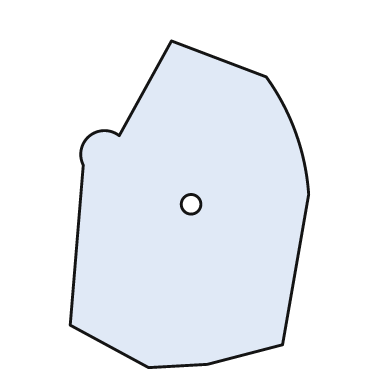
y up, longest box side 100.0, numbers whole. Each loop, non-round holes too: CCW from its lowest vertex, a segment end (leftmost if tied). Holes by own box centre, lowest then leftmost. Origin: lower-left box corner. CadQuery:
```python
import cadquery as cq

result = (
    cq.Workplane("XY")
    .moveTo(24.0, 0.0)
    .lineTo(42.0, 1.0)
    .lineTo(65.0, 7.0)
    .lineTo(73.0, 53.0)
    .threePointArc((69.0, 72.0), (60.0, 89.0))
    .lineTo(31.0, 100.0)
    .lineTo(15.0, 71.0)
    .threePointArc((6.0, 71.0), (4.0, 62.0))
    .lineTo(0.0, 13.0)
    .close()
    .moveTo(37.0, 50.0)
    .circle(3.0)
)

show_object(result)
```